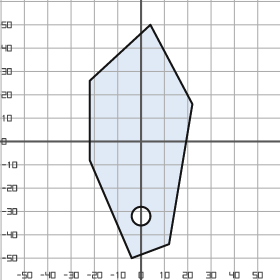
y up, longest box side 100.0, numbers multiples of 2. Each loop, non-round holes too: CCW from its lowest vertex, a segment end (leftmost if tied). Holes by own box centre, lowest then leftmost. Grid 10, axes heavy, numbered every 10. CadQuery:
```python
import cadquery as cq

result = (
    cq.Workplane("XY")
    .moveTo(-4.0, -50.0)
    .lineTo(12.0, -44.0)
    .lineTo(22.0, 16.0)
    .lineTo(4.0, 50.0)
    .lineTo(-22.0, 26.0)
    .lineTo(-22.0, -8.0)
    .close()
    .moveTo(0.0, -32.0)
    .circle(4.0)
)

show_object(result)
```